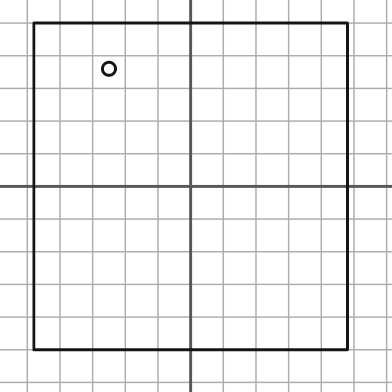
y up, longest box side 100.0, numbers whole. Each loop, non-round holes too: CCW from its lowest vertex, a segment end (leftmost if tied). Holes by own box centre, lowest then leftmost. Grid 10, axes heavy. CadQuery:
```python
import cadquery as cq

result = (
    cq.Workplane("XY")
    .moveTo(-48.0, -50.0)
    .lineTo(48.0, -50.0)
    .lineTo(48.0, 50.0)
    .lineTo(-48.0, 50.0)
    .close()
    .moveTo(-25.0, 36.0)
    .circle(2.0)
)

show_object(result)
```